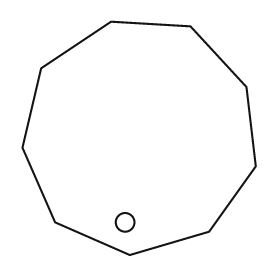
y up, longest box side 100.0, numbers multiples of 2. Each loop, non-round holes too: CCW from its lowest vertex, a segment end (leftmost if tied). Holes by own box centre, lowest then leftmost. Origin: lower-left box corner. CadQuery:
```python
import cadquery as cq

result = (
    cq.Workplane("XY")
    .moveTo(46.0, 0.0)
    .lineTo(80.0, 10.0)
    .lineTo(100.0, 38.0)
    .lineTo(96.0, 72.0)
    .lineTo(72.0, 98.0)
    .lineTo(38.0, 100.0)
    .lineTo(8.0, 80.0)
    .lineTo(0.0, 46.0)
    .lineTo(14.0, 14.0)
    .close()
    .moveTo(44.0, 14.0)
    .circle(4.0)
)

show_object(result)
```